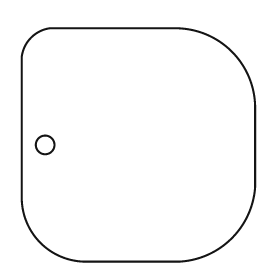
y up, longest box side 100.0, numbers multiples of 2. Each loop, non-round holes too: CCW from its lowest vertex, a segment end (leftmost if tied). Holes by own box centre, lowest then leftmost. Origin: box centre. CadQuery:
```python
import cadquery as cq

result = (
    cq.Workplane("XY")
    .moveTo(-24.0, -50.0)
    .lineTo(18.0, -50.0)
    .threePointArc((40.0, -40.0), (50.0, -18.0))
    .lineTo(50.0, 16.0)
    .threePointArc((40.0, 40.0), (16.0, 50.0))
    .lineTo(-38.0, 50.0)
    .threePointArc((-46.0, 46.0), (-50.0, 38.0))
    .lineTo(-50.0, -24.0)
    .threePointArc((-42.0, -42.0), (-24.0, -50.0))
    .close()
    .moveTo(-40.0, 0.0)
    .circle(4.0)
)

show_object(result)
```